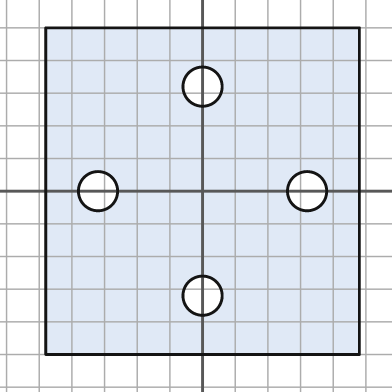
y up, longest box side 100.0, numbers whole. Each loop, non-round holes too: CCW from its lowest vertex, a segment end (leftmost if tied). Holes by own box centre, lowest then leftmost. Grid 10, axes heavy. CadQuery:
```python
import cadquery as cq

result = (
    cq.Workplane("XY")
    .moveTo(-48.0, -50.0)
    .lineTo(48.0, -50.0)
    .lineTo(48.0, 50.0)
    .lineTo(-48.0, 50.0)
    .close()
    .moveTo(0.0, -32.0)
    .circle(6.0)
    .moveTo(-32.0, 0.0)
    .circle(6.0)
    .moveTo(32.0, 0.0)
    .circle(6.0)
    .moveTo(0.0, 32.0)
    .circle(6.0)
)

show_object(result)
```